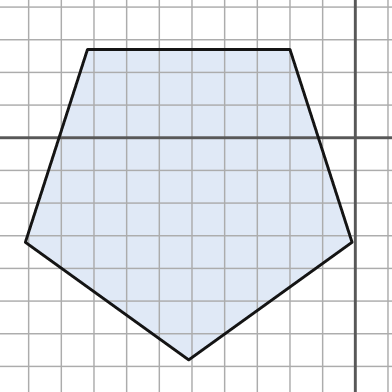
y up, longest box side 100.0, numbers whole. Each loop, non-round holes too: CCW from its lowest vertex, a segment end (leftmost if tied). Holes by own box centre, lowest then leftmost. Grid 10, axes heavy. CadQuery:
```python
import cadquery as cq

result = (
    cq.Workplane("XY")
    .moveTo(-51.0, -68.0)
    .lineTo(-1.0, -32.0)
    .lineTo(-20.0, 27.0)
    .lineTo(-82.0, 27.0)
    .lineTo(-101.0, -32.0)
    .close()
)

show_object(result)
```